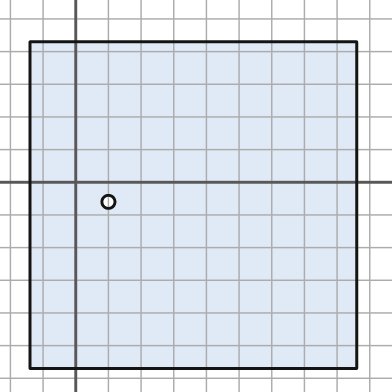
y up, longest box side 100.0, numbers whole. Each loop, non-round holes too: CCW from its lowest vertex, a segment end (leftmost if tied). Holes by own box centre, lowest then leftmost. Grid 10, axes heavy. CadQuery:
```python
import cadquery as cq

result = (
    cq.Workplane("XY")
    .moveTo(-14.0, -57.0)
    .lineTo(86.0, -57.0)
    .lineTo(86.0, 43.0)
    .lineTo(-14.0, 43.0)
    .close()
    .moveTo(10.0, -6.0)
    .circle(2.0)
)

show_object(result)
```